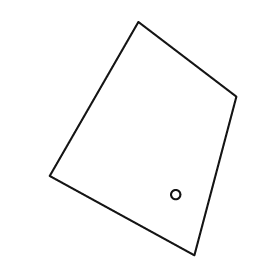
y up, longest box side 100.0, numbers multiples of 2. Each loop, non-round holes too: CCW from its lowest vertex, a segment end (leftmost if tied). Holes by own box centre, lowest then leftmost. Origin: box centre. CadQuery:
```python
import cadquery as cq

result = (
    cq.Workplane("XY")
    .moveTo(22.0, -50.0)
    .lineTo(40.0, 18.0)
    .lineTo(-2.0, 50.0)
    .lineTo(-40.0, -16.0)
    .close()
    .moveTo(14.0, -24.0)
    .circle(2.0)
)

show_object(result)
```